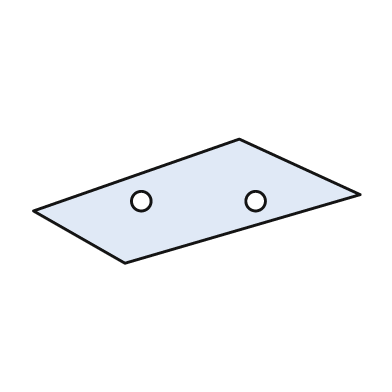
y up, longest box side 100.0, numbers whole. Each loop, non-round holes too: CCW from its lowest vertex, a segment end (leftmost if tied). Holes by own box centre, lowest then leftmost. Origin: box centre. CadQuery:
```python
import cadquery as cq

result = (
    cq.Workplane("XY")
    .moveTo(-22.0, -19.0)
    .lineTo(50.0, 2.0)
    .lineTo(13.0, 19.0)
    .lineTo(-50.0, -3.0)
    .close()
    .moveTo(-17.0, 0.0)
    .circle(3.0)
    .moveTo(18.0, 0.0)
    .circle(3.0)
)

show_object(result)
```